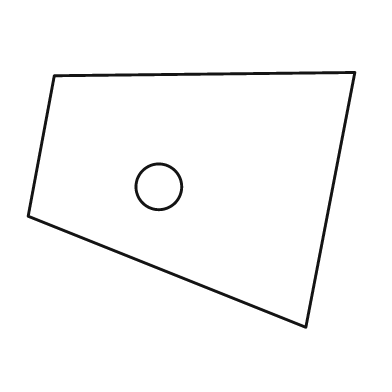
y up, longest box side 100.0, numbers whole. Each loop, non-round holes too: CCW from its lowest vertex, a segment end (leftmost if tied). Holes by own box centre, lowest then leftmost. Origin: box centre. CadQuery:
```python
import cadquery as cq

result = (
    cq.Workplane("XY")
    .moveTo(35.0, -39.0)
    .lineTo(50.0, 39.0)
    .lineTo(-42.0, 38.0)
    .lineTo(-50.0, -5.0)
    .close()
    .moveTo(-10.0, 4.0)
    .circle(7.0)
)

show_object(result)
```